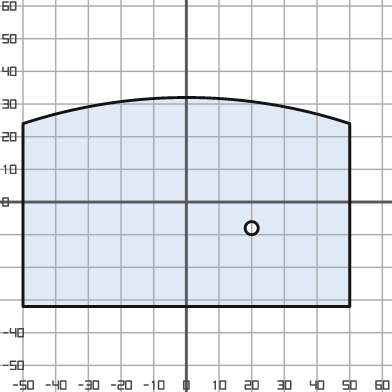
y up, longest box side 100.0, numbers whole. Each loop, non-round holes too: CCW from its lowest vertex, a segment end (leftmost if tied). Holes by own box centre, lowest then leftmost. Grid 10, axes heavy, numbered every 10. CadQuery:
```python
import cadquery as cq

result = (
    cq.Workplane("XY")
    .moveTo(-50.0, -32.0)
    .lineTo(50.0, -32.0)
    .lineTo(50.0, 24.0)
    .threePointArc((0.0, 32.0), (-50.0, 24.0))
    .close()
    .moveTo(20.0, -8.0)
    .circle(2.0)
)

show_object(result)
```